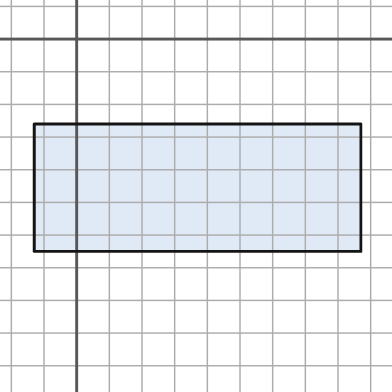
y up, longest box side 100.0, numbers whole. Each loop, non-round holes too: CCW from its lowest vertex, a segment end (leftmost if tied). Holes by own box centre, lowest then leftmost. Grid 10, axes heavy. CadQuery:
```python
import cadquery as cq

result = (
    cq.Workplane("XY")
    .moveTo(-13.0, -65.0)
    .lineTo(87.0, -65.0)
    .lineTo(87.0, -26.0)
    .lineTo(-13.0, -26.0)
    .close()
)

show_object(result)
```